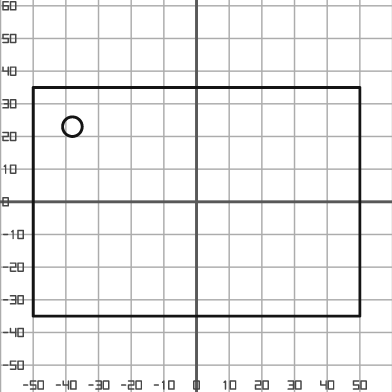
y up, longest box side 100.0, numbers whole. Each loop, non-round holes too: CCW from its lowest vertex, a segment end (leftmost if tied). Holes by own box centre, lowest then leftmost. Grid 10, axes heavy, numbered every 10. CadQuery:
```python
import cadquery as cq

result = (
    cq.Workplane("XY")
    .moveTo(-50.0, -35.0)
    .lineTo(50.0, -35.0)
    .lineTo(50.0, 35.0)
    .lineTo(-50.0, 35.0)
    .close()
    .moveTo(-38.0, 23.0)
    .circle(3.0)
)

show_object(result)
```